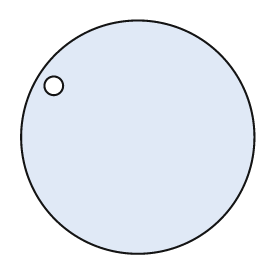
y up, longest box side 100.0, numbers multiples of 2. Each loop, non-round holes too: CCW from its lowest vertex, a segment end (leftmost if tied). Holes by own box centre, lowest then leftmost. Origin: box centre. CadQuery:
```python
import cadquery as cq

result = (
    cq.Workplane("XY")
    .moveTo(0.0, 0.0)
    .circle(50.0)
    .moveTo(-36.0, 22.0)
    .circle(4.0)
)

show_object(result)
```